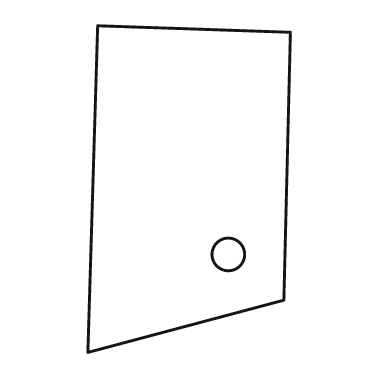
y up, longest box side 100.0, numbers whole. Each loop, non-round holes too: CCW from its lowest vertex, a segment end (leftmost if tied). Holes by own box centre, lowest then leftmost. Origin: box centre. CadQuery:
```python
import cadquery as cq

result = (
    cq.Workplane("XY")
    .moveTo(-31.0, -50.0)
    .lineTo(29.0, -34.0)
    .lineTo(31.0, 48.0)
    .lineTo(-28.0, 50.0)
    .close()
    .moveTo(12.0, -20.0)
    .circle(5.0)
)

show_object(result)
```